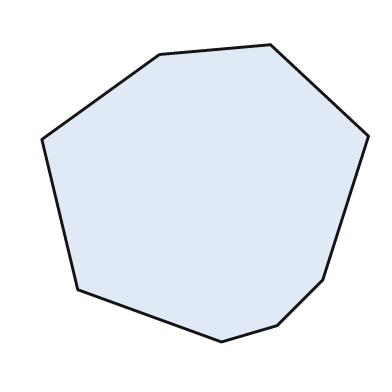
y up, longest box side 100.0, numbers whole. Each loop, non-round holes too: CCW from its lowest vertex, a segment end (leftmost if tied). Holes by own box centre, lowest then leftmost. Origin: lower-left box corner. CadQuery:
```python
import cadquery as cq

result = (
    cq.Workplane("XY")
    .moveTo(55.0, 0.0)
    .lineTo(72.0, 5.0)
    .lineTo(86.0, 19.0)
    .lineTo(100.0, 63.0)
    .lineTo(70.0, 91.0)
    .lineTo(36.0, 88.0)
    .lineTo(0.0, 62.0)
    .lineTo(11.0, 16.0)
    .close()
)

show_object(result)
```